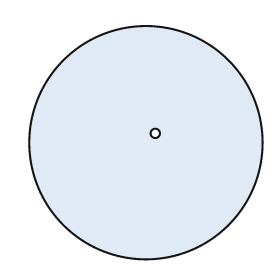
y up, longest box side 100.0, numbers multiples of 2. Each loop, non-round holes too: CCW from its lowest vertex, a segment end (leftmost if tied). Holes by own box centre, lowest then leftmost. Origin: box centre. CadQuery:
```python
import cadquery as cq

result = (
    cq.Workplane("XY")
    .moveTo(0.0, 0.0)
    .circle(50.0)
    .moveTo(4.0, 4.0)
    .circle(2.0)
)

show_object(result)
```